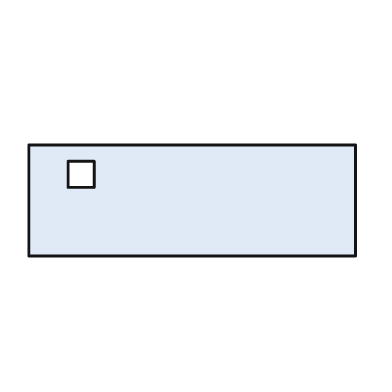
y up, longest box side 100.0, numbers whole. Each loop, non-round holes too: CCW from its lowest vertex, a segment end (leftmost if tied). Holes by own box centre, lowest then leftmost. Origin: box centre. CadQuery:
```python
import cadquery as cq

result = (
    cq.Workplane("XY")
    .moveTo(-50.0, -17.0)
    .lineTo(50.0, -17.0)
    .lineTo(50.0, 17.0)
    .lineTo(-50.0, 17.0)
    .close()
    .moveTo(-38.0, 4.0)
    .lineTo(-30.0, 4.0)
    .lineTo(-30.0, 12.0)
    .lineTo(-38.0, 12.0)
    .close()
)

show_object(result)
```